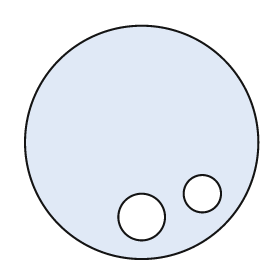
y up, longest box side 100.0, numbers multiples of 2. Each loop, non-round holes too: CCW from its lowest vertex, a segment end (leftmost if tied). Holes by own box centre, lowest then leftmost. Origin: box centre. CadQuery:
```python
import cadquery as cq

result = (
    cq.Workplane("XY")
    .moveTo(0.0, 0.0)
    .circle(50.0)
    .moveTo(0.0, -32.0)
    .circle(10.0)
    .moveTo(26.0, -22.0)
    .circle(8.0)
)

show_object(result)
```